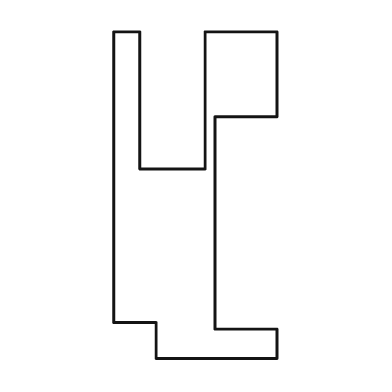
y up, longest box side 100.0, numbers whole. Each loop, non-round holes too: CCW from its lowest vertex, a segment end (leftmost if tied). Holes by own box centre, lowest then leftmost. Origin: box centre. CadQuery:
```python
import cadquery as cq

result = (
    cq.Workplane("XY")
    .moveTo(-12.0, -50.0)
    .lineTo(25.0, -50.0)
    .lineTo(25.0, -41.0)
    .lineTo(6.0, -41.0)
    .lineTo(6.0, 24.0)
    .lineTo(25.0, 24.0)
    .lineTo(25.0, 50.0)
    .lineTo(3.0, 50.0)
    .lineTo(3.0, 8.0)
    .lineTo(-17.0, 8.0)
    .lineTo(-17.0, 50.0)
    .lineTo(-25.0, 50.0)
    .lineTo(-25.0, -39.0)
    .lineTo(-12.0, -39.0)
    .close()
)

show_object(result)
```